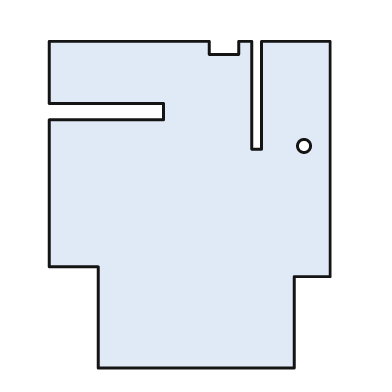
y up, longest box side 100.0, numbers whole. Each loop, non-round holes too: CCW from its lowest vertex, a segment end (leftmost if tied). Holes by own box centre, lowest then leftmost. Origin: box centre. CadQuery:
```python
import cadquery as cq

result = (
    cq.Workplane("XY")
    .moveTo(-28.0, -50.0)
    .lineTo(32.0, -50.0)
    .lineTo(32.0, -22.0)
    .lineTo(43.0, -22.0)
    .lineTo(43.0, 50.0)
    .lineTo(22.0, 50.0)
    .lineTo(22.0, 17.0)
    .lineTo(19.0, 17.0)
    .lineTo(19.0, 50.0)
    .lineTo(15.0, 50.0)
    .lineTo(15.0, 46.0)
    .lineTo(6.0, 46.0)
    .lineTo(6.0, 50.0)
    .lineTo(-43.0, 50.0)
    .lineTo(-43.0, 31.0)
    .lineTo(-8.0, 31.0)
    .lineTo(-8.0, 26.0)
    .lineTo(-43.0, 26.0)
    .lineTo(-43.0, -19.0)
    .lineTo(-28.0, -19.0)
    .close()
    .moveTo(35.0, 18.0)
    .circle(2.0)
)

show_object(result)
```